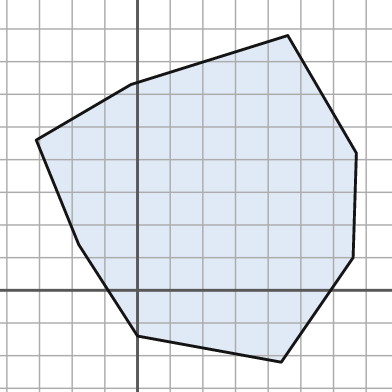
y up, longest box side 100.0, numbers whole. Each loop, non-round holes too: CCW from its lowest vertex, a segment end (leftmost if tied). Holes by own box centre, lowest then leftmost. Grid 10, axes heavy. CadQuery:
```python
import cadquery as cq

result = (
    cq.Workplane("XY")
    .moveTo(44.0, -22.0)
    .lineTo(66.0, 10.0)
    .lineTo(67.0, 42.0)
    .lineTo(46.0, 78.0)
    .lineTo(-2.0, 63.0)
    .lineTo(-31.0, 46.0)
    .lineTo(-18.0, 14.0)
    .lineTo(0.0, -14.0)
    .close()
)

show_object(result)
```